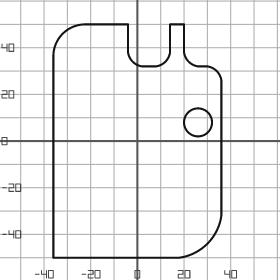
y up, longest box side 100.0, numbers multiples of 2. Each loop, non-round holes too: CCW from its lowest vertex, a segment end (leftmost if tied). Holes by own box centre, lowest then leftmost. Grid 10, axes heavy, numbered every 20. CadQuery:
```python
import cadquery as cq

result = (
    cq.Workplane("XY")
    .moveTo(-36.0, -50.0)
    .lineTo(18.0, -50.0)
    .threePointArc((30.0, -44.0), (36.0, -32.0))
    .lineTo(36.0, 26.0)
    .threePointArc((34.0, 30.0), (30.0, 32.0))
    .lineTo(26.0, 32.0)
    .threePointArc((22.0, 34.0), (20.0, 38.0))
    .lineTo(20.0, 50.0)
    .lineTo(14.0, 50.0)
    .lineTo(14.0, 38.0)
    .threePointArc((12.0, 34.0), (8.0, 32.0))
    .lineTo(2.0, 32.0)
    .threePointArc((-2.0, 34.0), (-4.0, 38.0))
    .lineTo(-4.0, 50.0)
    .lineTo(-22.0, 50.0)
    .threePointArc((-32.0, 46.0), (-36.0, 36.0))
    .close()
    .moveTo(26.0, 8.0)
    .circle(6.0)
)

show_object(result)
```